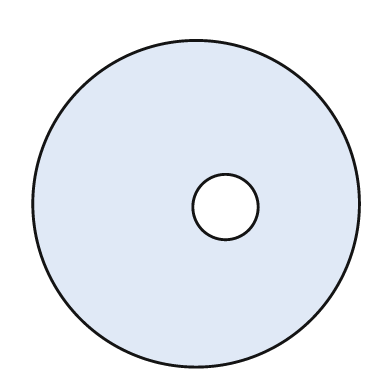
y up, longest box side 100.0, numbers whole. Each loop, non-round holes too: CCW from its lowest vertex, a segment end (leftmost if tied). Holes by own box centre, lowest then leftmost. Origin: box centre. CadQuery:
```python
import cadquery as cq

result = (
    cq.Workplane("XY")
    .moveTo(0.0, 0.0)
    .circle(50.0)
    .moveTo(9.0, -1.0)
    .circle(10.0)
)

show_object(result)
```